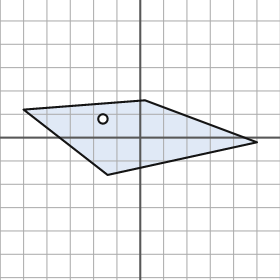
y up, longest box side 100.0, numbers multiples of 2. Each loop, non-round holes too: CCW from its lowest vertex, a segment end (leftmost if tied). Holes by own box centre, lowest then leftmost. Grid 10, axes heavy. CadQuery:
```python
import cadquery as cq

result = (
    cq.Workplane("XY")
    .moveTo(-14.0, -16.0)
    .lineTo(50.0, -2.0)
    .lineTo(2.0, 16.0)
    .lineTo(-50.0, 12.0)
    .close()
    .moveTo(-16.0, 8.0)
    .circle(2.0)
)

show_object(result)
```